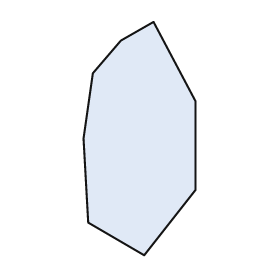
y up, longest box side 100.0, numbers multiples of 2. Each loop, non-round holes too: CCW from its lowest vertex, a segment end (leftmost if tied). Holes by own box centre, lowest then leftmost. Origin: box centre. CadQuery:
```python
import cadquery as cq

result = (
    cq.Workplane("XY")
    .moveTo(2.0, -50.0)
    .lineTo(24.0, -22.0)
    .lineTo(24.0, 16.0)
    .lineTo(6.0, 50.0)
    .lineTo(-8.0, 42.0)
    .lineTo(-20.0, 28.0)
    .lineTo(-24.0, 0.0)
    .lineTo(-22.0, -36.0)
    .close()
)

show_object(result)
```